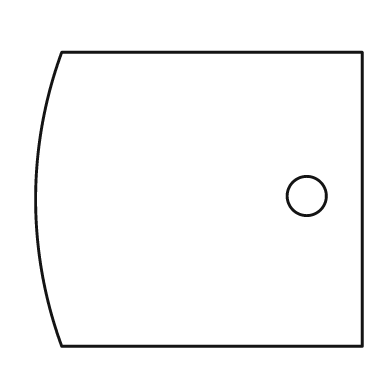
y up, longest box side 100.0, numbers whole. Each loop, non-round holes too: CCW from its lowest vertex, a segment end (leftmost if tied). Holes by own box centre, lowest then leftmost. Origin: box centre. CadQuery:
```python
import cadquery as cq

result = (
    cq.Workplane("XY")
    .moveTo(-42.0, -45.0)
    .lineTo(50.0, -45.0)
    .lineTo(50.0, 45.0)
    .lineTo(-42.0, 45.0)
    .threePointArc((-50.0, 0.0), (-42.0, -45.0))
    .close()
    .moveTo(33.0, 1.0)
    .circle(6.0)
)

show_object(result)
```